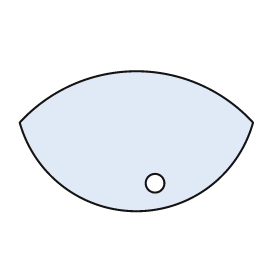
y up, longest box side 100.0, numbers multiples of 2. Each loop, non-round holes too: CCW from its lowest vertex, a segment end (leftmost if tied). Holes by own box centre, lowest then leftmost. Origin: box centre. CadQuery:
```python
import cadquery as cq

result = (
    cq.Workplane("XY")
    .moveTo(-50.0, 8.0)
    .threePointArc((0.0, -30.0), (50.0, 8.0))
    .threePointArc((0.0, 30.0), (-50.0, 8.0))
    .close()
    .moveTo(8.0, -18.0)
    .circle(4.0)
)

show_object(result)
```